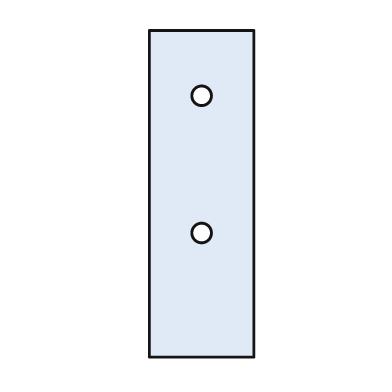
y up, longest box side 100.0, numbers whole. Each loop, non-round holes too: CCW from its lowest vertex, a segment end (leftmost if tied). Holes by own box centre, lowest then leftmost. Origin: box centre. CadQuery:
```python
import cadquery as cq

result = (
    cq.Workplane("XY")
    .moveTo(-16.0, -50.0)
    .lineTo(16.0, -50.0)
    .lineTo(16.0, 50.0)
    .lineTo(-16.0, 50.0)
    .close()
    .moveTo(0.0, -12.0)
    .circle(3.0)
    .moveTo(0.0, 30.0)
    .circle(3.0)
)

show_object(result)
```